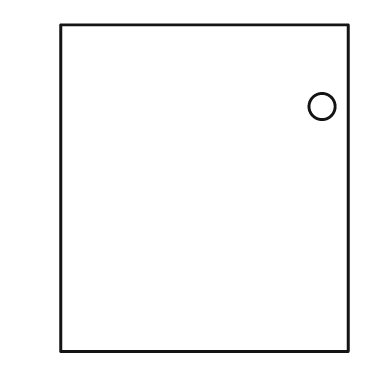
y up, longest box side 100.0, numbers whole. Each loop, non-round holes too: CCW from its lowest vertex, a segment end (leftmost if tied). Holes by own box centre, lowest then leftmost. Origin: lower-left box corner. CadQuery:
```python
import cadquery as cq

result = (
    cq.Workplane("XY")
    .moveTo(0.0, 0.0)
    .lineTo(88.0, 0.0)
    .lineTo(88.0, 100.0)
    .lineTo(0.0, 100.0)
    .close()
    .moveTo(80.0, 75.0)
    .circle(4.0)
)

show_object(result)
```